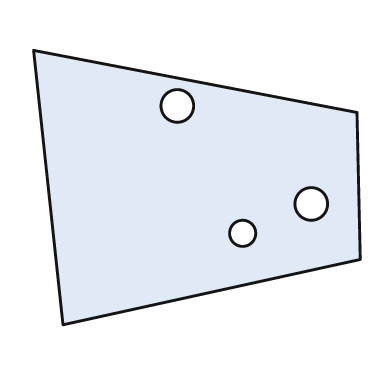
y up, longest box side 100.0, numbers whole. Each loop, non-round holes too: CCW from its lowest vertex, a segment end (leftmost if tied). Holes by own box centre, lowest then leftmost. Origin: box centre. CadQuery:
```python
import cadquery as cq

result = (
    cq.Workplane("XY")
    .moveTo(-41.0, -42.0)
    .lineTo(50.0, -22.0)
    .lineTo(49.0, 23.0)
    .lineTo(-50.0, 42.0)
    .close()
    .moveTo(14.0, -14.0)
    .circle(4.0)
    .moveTo(35.0, -5.0)
    .circle(5.0)
    .moveTo(-6.0, 25.0)
    .circle(5.0)
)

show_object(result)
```